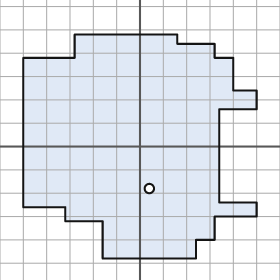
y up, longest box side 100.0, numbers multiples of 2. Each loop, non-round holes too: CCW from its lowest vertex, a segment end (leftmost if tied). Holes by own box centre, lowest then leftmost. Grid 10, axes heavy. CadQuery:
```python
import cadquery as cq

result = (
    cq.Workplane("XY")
    .moveTo(-16.0, -48.0)
    .lineTo(24.0, -48.0)
    .lineTo(24.0, -40.0)
    .lineTo(32.0, -40.0)
    .lineTo(32.0, -30.0)
    .lineTo(50.0, -30.0)
    .lineTo(50.0, -24.0)
    .lineTo(34.0, -24.0)
    .lineTo(34.0, 16.0)
    .lineTo(50.0, 16.0)
    .lineTo(50.0, 24.0)
    .lineTo(40.0, 24.0)
    .lineTo(40.0, 38.0)
    .lineTo(32.0, 38.0)
    .lineTo(32.0, 44.0)
    .lineTo(16.0, 44.0)
    .lineTo(16.0, 48.0)
    .lineTo(-28.0, 48.0)
    .lineTo(-28.0, 38.0)
    .lineTo(-50.0, 38.0)
    .lineTo(-50.0, -26.0)
    .lineTo(-32.0, -26.0)
    .lineTo(-32.0, -32.0)
    .lineTo(-16.0, -32.0)
    .close()
    .moveTo(4.0, -18.0)
    .circle(2.0)
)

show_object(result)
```